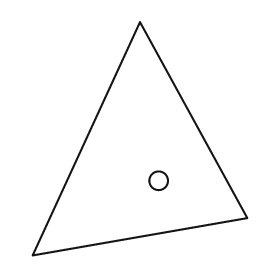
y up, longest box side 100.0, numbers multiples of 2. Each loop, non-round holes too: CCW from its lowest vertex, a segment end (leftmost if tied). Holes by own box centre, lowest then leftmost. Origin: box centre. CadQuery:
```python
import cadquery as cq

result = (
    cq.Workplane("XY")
    .moveTo(-46.0, -50.0)
    .lineTo(46.0, -34.0)
    .lineTo(0.0, 50.0)
    .close()
    .moveTo(8.0, -18.0)
    .circle(4.0)
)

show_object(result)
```